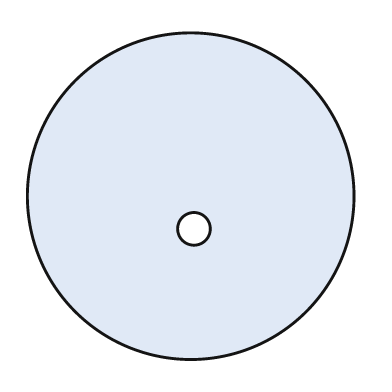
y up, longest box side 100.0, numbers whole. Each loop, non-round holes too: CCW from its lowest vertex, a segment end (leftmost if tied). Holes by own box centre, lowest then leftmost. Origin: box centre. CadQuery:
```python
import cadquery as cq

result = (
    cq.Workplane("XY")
    .moveTo(0.0, 0.0)
    .circle(50.0)
    .moveTo(1.0, -10.0)
    .circle(5.0)
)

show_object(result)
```